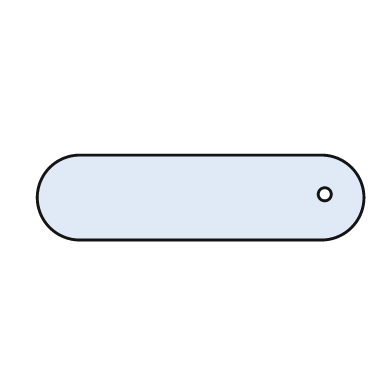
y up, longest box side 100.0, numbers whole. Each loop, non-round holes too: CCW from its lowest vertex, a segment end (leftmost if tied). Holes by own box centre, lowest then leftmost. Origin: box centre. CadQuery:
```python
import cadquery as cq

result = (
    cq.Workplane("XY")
    .moveTo(-37.0, -13.0)
    .lineTo(37.0, -13.0)
    .threePointArc((50.0, 0.0), (37.0, 13.0))
    .lineTo(-37.0, 13.0)
    .threePointArc((-50.0, 0.0), (-37.0, -13.0))
    .close()
    .moveTo(38.0, 1.0)
    .circle(2.0)
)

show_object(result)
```